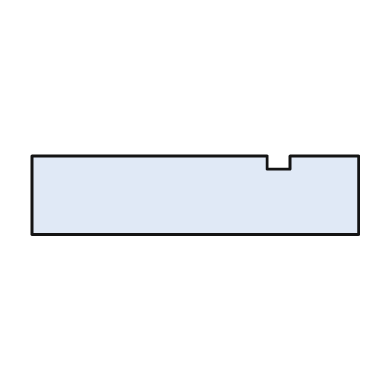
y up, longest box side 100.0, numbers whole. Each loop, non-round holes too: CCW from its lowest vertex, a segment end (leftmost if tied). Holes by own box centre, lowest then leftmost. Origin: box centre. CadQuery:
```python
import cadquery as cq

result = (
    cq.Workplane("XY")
    .moveTo(-50.0, -12.0)
    .lineTo(50.0, -12.0)
    .lineTo(50.0, 12.0)
    .lineTo(29.0, 12.0)
    .lineTo(29.0, 8.0)
    .lineTo(22.0, 8.0)
    .lineTo(22.0, 12.0)
    .lineTo(-50.0, 12.0)
    .close()
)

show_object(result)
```